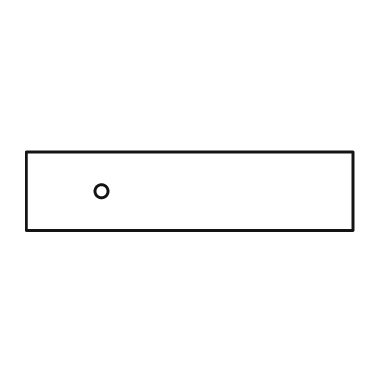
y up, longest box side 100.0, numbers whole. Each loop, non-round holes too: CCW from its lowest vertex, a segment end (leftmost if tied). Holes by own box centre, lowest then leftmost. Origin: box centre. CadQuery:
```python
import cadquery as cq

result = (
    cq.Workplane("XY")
    .moveTo(-50.0, -12.0)
    .lineTo(50.0, -12.0)
    .lineTo(50.0, 12.0)
    .lineTo(-50.0, 12.0)
    .close()
    .moveTo(-27.0, 0.0)
    .circle(2.0)
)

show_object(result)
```